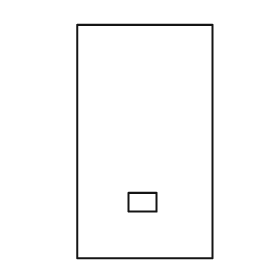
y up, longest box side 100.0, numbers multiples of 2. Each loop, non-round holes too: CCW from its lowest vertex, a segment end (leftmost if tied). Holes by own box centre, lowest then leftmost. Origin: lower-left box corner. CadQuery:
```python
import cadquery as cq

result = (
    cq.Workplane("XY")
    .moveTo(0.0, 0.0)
    .lineTo(58.0, 0.0)
    .lineTo(58.0, 100.0)
    .lineTo(0.0, 100.0)
    .close()
    .moveTo(22.0, 20.0)
    .lineTo(34.0, 20.0)
    .lineTo(34.0, 28.0)
    .lineTo(22.0, 28.0)
    .close()
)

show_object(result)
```